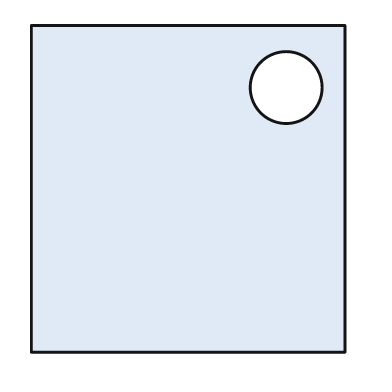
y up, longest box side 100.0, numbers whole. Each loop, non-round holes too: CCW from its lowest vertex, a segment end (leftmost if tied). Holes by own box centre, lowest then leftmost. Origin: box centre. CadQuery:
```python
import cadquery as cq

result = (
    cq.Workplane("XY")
    .moveTo(-48.0, -50.0)
    .lineTo(48.0, -50.0)
    .lineTo(48.0, 50.0)
    .lineTo(-48.0, 50.0)
    .close()
    .moveTo(30.0, 31.0)
    .circle(11.0)
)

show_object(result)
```